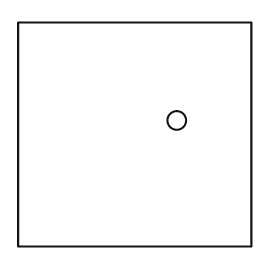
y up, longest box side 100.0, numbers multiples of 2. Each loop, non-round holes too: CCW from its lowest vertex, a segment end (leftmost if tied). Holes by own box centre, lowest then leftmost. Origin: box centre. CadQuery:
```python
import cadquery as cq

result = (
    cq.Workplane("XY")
    .moveTo(-50.0, -48.0)
    .lineTo(50.0, -48.0)
    .lineTo(50.0, 48.0)
    .lineTo(-50.0, 48.0)
    .close()
    .moveTo(18.0, 6.0)
    .circle(4.0)
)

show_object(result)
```